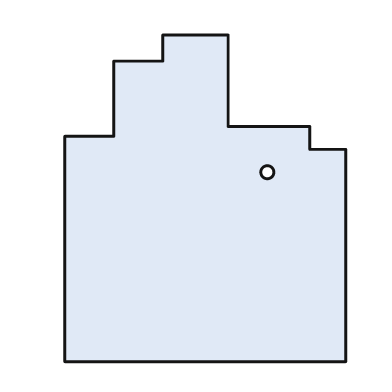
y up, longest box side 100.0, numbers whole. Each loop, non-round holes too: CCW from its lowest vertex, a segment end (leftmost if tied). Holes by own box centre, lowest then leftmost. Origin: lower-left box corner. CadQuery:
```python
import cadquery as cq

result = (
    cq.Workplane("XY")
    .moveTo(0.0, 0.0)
    .lineTo(86.0, 0.0)
    .lineTo(86.0, 65.0)
    .lineTo(75.0, 65.0)
    .lineTo(75.0, 72.0)
    .lineTo(50.0, 72.0)
    .lineTo(50.0, 100.0)
    .lineTo(30.0, 100.0)
    .lineTo(30.0, 92.0)
    .lineTo(15.0, 92.0)
    .lineTo(15.0, 69.0)
    .lineTo(0.0, 69.0)
    .close()
    .moveTo(62.0, 58.0)
    .circle(2.0)
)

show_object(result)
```